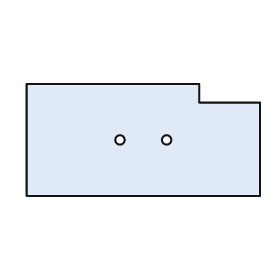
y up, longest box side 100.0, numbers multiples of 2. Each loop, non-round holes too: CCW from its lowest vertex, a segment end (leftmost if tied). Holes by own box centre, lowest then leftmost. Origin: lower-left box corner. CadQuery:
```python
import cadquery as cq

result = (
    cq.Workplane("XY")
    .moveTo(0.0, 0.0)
    .lineTo(100.0, 0.0)
    .lineTo(100.0, 40.0)
    .lineTo(74.0, 40.0)
    .lineTo(74.0, 48.0)
    .lineTo(0.0, 48.0)
    .close()
    .moveTo(40.0, 24.0)
    .circle(2.0)
    .moveTo(60.0, 24.0)
    .circle(2.0)
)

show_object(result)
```